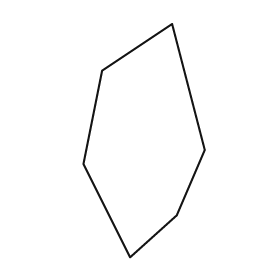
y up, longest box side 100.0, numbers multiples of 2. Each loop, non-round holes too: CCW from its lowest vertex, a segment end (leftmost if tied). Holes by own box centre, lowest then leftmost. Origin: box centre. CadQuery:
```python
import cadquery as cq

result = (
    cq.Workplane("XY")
    .moveTo(-6.0, -50.0)
    .lineTo(14.0, -32.0)
    .lineTo(26.0, -4.0)
    .lineTo(12.0, 50.0)
    .lineTo(-18.0, 30.0)
    .lineTo(-26.0, -10.0)
    .close()
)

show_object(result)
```